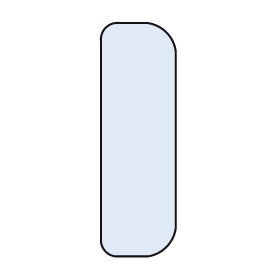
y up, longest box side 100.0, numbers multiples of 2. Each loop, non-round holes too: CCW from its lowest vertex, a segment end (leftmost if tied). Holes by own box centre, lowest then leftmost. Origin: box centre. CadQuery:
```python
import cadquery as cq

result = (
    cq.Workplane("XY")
    .moveTo(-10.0, -50.0)
    .lineTo(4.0, -50.0)
    .threePointArc((12.0, -46.0), (16.0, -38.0))
    .lineTo(16.0, 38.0)
    .threePointArc((12.0, 46.0), (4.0, 50.0))
    .lineTo(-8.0, 50.0)
    .threePointArc((-14.0, 48.0), (-16.0, 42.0))
    .lineTo(-16.0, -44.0)
    .threePointArc((-14.0, -48.0), (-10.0, -50.0))
    .close()
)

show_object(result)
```